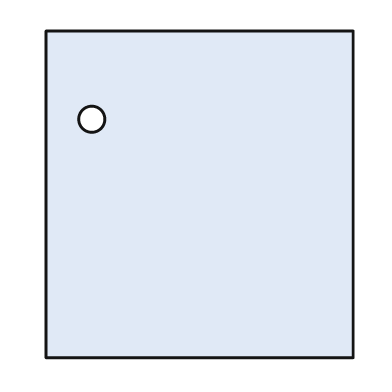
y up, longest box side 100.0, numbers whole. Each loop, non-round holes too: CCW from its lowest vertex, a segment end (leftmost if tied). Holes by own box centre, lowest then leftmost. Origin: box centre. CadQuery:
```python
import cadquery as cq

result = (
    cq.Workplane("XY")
    .moveTo(-47.0, -50.0)
    .lineTo(47.0, -50.0)
    .lineTo(47.0, 50.0)
    .lineTo(-47.0, 50.0)
    .close()
    .moveTo(-33.0, 23.0)
    .circle(4.0)
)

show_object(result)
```